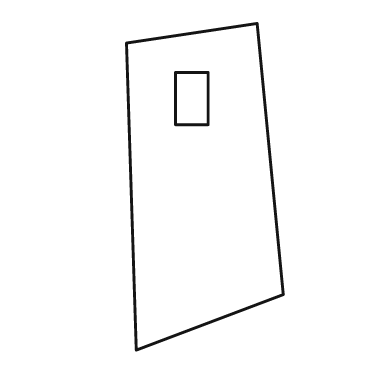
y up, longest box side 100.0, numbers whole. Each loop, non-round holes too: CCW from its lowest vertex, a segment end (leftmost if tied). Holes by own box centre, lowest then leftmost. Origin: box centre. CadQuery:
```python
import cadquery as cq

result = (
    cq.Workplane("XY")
    .moveTo(-21.0, -50.0)
    .lineTo(24.0, -33.0)
    .lineTo(16.0, 50.0)
    .lineTo(-24.0, 44.0)
    .close()
    .moveTo(-9.0, 19.0)
    .lineTo(1.0, 19.0)
    .lineTo(1.0, 35.0)
    .lineTo(-9.0, 35.0)
    .close()
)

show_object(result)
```